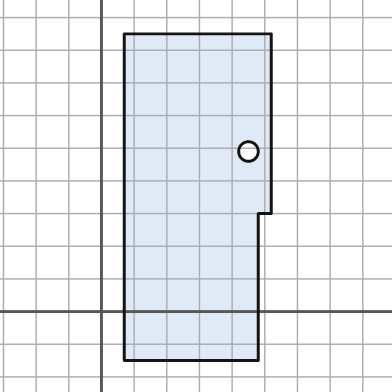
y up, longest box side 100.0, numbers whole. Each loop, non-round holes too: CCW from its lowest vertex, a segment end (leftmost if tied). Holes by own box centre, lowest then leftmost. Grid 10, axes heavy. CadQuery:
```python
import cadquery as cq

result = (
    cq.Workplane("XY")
    .moveTo(7.0, -15.0)
    .lineTo(48.0, -15.0)
    .lineTo(48.0, 30.0)
    .lineTo(52.0, 30.0)
    .lineTo(52.0, 85.0)
    .lineTo(7.0, 85.0)
    .close()
    .moveTo(45.0, 49.0)
    .circle(3.0)
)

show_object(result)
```